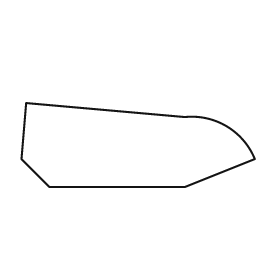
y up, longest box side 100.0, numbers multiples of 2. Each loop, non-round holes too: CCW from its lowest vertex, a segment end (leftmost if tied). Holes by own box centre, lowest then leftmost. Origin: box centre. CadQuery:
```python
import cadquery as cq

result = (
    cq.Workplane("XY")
    .moveTo(-38.0, -18.0)
    .lineTo(20.0, -18.0)
    .lineTo(50.0, -6.0)
    .threePointArc((38.0, 8.0), (20.0, 12.0))
    .lineTo(-48.0, 18.0)
    .lineTo(-50.0, -6.0)
    .close()
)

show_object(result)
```